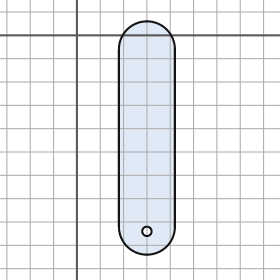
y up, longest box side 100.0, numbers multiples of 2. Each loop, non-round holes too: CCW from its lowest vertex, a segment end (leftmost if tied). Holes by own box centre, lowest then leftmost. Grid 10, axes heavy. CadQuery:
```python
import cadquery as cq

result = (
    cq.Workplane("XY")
    .moveTo(18.0, -82.0)
    .threePointArc((30.0, -94.0), (42.0, -82.0))
    .lineTo(42.0, -6.0)
    .threePointArc((30.0, 6.0), (18.0, -6.0))
    .close()
    .moveTo(30.0, -84.0)
    .circle(2.0)
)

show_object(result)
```